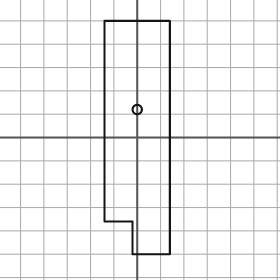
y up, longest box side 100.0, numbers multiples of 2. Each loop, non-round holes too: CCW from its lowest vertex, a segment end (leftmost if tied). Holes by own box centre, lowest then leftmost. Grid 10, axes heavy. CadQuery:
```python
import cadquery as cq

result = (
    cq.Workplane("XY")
    .moveTo(-2.0, -50.0)
    .lineTo(14.0, -50.0)
    .lineTo(14.0, 50.0)
    .lineTo(-14.0, 50.0)
    .lineTo(-14.0, -36.0)
    .lineTo(-2.0, -36.0)
    .close()
    .moveTo(0.0, 12.0)
    .circle(2.0)
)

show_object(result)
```